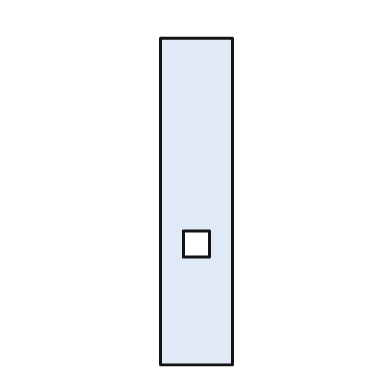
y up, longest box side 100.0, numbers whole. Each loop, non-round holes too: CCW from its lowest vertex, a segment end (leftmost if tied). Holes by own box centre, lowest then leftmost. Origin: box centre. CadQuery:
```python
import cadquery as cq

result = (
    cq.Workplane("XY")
    .moveTo(-11.0, -50.0)
    .lineTo(11.0, -50.0)
    .lineTo(11.0, 50.0)
    .lineTo(-11.0, 50.0)
    .close()
    .moveTo(-4.0, -17.0)
    .lineTo(4.0, -17.0)
    .lineTo(4.0, -9.0)
    .lineTo(-4.0, -9.0)
    .close()
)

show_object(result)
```